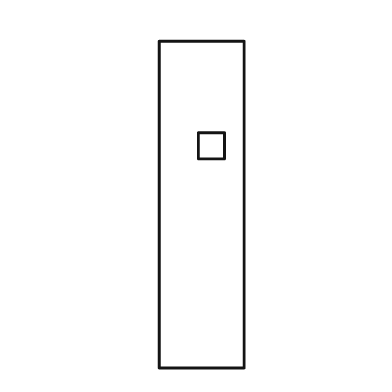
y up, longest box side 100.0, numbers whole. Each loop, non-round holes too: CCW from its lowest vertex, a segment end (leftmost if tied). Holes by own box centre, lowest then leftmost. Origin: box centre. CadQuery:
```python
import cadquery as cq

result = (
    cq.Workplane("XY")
    .moveTo(-13.0, -50.0)
    .lineTo(13.0, -50.0)
    .lineTo(13.0, 50.0)
    .lineTo(-13.0, 50.0)
    .close()
    .moveTo(-1.0, 14.0)
    .lineTo(7.0, 14.0)
    .lineTo(7.0, 22.0)
    .lineTo(-1.0, 22.0)
    .close()
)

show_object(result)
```